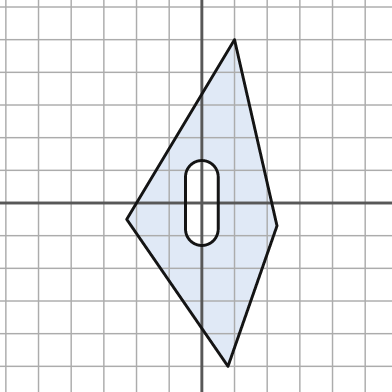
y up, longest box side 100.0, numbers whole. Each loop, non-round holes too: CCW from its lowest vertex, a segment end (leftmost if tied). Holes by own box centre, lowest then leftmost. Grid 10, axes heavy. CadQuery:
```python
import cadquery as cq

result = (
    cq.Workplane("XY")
    .moveTo(8.0, -50.0)
    .lineTo(23.0, -7.0)
    .lineTo(10.0, 50.0)
    .lineTo(-23.0, -5.0)
    .close()
    .moveTo(-5.0, -8.0)
    .threePointArc((0.0, -13.0), (5.0, -8.0))
    .lineTo(5.0, 8.0)
    .threePointArc((0.0, 13.0), (-5.0, 8.0))
    .close()
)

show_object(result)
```